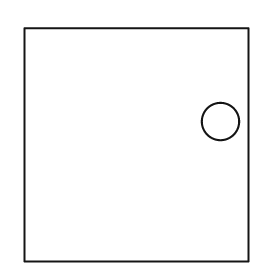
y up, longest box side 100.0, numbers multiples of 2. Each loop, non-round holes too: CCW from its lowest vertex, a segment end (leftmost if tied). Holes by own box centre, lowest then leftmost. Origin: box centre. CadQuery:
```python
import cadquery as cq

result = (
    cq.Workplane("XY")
    .moveTo(-48.0, -50.0)
    .lineTo(48.0, -50.0)
    .lineTo(48.0, 50.0)
    .lineTo(-48.0, 50.0)
    .close()
    .moveTo(36.0, 10.0)
    .circle(8.0)
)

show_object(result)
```